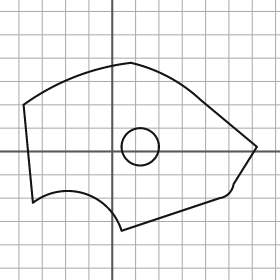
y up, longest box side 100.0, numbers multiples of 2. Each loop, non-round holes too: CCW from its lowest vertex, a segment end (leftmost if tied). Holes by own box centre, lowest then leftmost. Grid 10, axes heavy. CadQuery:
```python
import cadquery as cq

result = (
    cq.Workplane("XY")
    .moveTo(4.0, -34.0)
    .lineTo(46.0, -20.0)
    .threePointArc((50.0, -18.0), (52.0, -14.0))
    .lineTo(62.0, 2.0)
    .lineTo(38.0, 22.0)
    .threePointArc((24.0, 32.0), (8.0, 38.0))
    .threePointArc((-16.0, 32.0), (-38.0, 20.0))
    .lineTo(-34.0, -22.0)
    .threePointArc((-12.0, -18.0), (4.0, -34.0))
    .close()
    .moveTo(12.0, 2.0)
    .circle(8.0)
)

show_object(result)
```